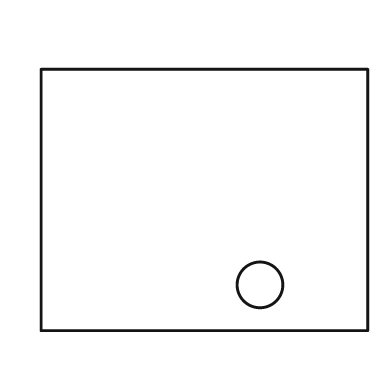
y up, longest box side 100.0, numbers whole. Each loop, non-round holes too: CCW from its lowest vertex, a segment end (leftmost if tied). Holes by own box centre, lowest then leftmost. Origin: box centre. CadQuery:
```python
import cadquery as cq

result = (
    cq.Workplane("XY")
    .moveTo(-50.0, -40.0)
    .lineTo(50.0, -40.0)
    .lineTo(50.0, 40.0)
    .lineTo(-50.0, 40.0)
    .close()
    .moveTo(17.0, -26.0)
    .circle(7.0)
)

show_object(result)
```